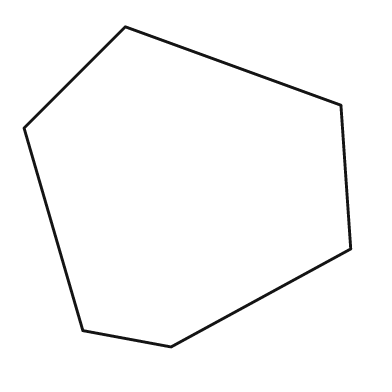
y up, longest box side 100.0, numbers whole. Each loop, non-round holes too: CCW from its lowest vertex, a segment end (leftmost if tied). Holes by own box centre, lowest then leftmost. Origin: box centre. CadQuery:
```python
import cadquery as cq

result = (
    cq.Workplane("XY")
    .moveTo(-5.0, -49.0)
    .lineTo(50.0, -19.0)
    .lineTo(47.0, 25.0)
    .lineTo(-19.0, 49.0)
    .lineTo(-50.0, 18.0)
    .lineTo(-32.0, -44.0)
    .close()
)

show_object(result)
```